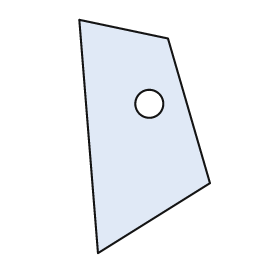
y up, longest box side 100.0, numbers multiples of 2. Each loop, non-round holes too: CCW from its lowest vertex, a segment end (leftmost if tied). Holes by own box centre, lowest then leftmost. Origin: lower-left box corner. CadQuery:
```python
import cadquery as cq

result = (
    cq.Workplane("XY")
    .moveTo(8.0, 0.0)
    .lineTo(56.0, 30.0)
    .lineTo(38.0, 92.0)
    .lineTo(0.0, 100.0)
    .close()
    .moveTo(30.0, 64.0)
    .circle(6.0)
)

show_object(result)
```